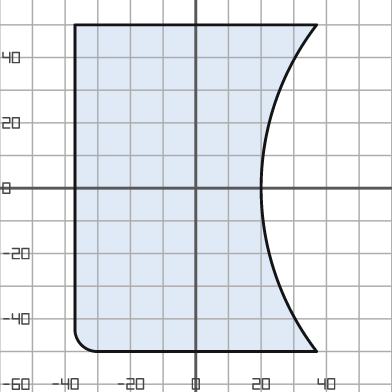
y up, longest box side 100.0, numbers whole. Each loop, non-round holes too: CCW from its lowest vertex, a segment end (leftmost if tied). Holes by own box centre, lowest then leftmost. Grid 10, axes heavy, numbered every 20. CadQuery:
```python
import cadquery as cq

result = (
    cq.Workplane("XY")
    .moveTo(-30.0, -50.0)
    .lineTo(37.0, -50.0)
    .threePointArc((20.0, 0.0), (37.0, 50.0))
    .lineTo(-37.0, 50.0)
    .lineTo(-37.0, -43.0)
    .threePointArc((-35.0, -48.0), (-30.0, -50.0))
    .close()
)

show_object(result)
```